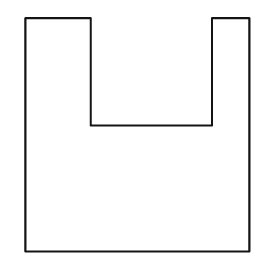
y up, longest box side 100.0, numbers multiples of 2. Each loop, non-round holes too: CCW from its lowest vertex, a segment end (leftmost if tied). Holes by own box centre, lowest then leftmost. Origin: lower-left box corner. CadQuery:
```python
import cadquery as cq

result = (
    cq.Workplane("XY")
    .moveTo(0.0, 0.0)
    .lineTo(96.0, 0.0)
    .lineTo(96.0, 100.0)
    .lineTo(80.0, 100.0)
    .lineTo(80.0, 54.0)
    .lineTo(28.0, 54.0)
    .lineTo(28.0, 100.0)
    .lineTo(0.0, 100.0)
    .close()
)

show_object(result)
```